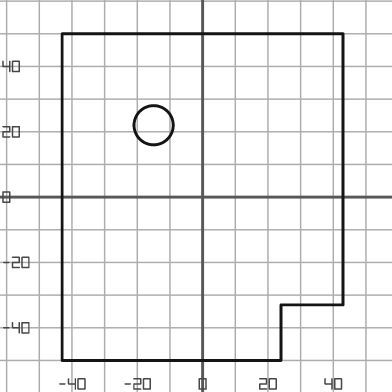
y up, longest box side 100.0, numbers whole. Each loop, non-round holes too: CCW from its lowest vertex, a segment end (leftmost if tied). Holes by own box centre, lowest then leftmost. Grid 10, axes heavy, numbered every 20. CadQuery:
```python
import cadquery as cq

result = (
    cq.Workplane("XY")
    .moveTo(-43.0, -50.0)
    .lineTo(24.0, -50.0)
    .lineTo(24.0, -33.0)
    .lineTo(43.0, -33.0)
    .lineTo(43.0, 50.0)
    .lineTo(-43.0, 50.0)
    .close()
    .moveTo(-15.0, 22.0)
    .circle(6.0)
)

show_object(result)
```